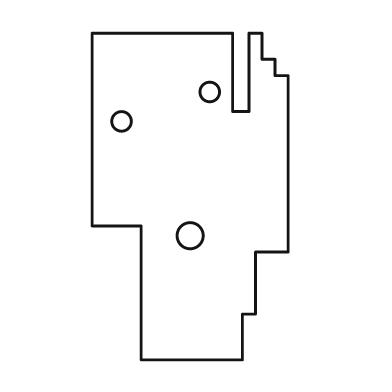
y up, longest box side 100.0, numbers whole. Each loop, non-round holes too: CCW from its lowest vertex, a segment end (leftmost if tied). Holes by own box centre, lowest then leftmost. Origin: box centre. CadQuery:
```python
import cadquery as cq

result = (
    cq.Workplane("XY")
    .moveTo(-15.0, -50.0)
    .lineTo(16.0, -50.0)
    .lineTo(16.0, -36.0)
    .lineTo(20.0, -36.0)
    .lineTo(20.0, -17.0)
    .lineTo(30.0, -17.0)
    .lineTo(30.0, 37.0)
    .lineTo(26.0, 37.0)
    .lineTo(26.0, 42.0)
    .lineTo(22.0, 42.0)
    .lineTo(22.0, 50.0)
    .lineTo(18.0, 50.0)
    .lineTo(18.0, 26.0)
    .lineTo(13.0, 26.0)
    .lineTo(13.0, 50.0)
    .lineTo(-30.0, 50.0)
    .lineTo(-30.0, -9.0)
    .lineTo(-15.0, -9.0)
    .close()
    .moveTo(0.0, -12.0)
    .circle(4.0)
    .moveTo(-21.0, 23.0)
    .circle(3.0)
    .moveTo(6.0, 32.0)
    .circle(3.0)
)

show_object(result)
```